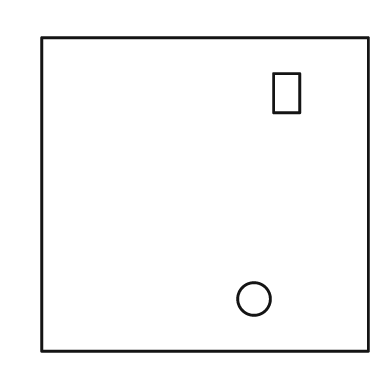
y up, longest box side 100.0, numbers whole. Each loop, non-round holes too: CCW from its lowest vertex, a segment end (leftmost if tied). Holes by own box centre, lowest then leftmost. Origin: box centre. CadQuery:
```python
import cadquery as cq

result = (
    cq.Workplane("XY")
    .moveTo(-50.0, -48.0)
    .lineTo(50.0, -48.0)
    .lineTo(50.0, 48.0)
    .lineTo(-50.0, 48.0)
    .close()
    .moveTo(15.0, -32.0)
    .circle(5.0)
    .moveTo(21.0, 25.0)
    .lineTo(29.0, 25.0)
    .lineTo(29.0, 37.0)
    .lineTo(21.0, 37.0)
    .close()
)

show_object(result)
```